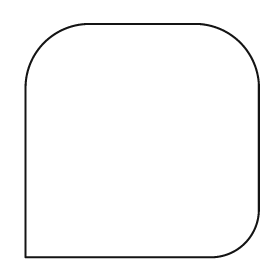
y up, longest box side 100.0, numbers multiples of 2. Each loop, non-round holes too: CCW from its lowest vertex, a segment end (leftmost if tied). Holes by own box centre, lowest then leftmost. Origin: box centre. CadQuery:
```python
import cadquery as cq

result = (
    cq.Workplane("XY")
    .moveTo(-50.0, -50.0)
    .lineTo(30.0, -50.0)
    .threePointArc((44.0, -44.0), (50.0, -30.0))
    .lineTo(50.0, 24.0)
    .threePointArc((42.0, 42.0), (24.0, 50.0))
    .lineTo(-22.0, 50.0)
    .threePointArc((-42.0, 42.0), (-50.0, 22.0))
    .close()
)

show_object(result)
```